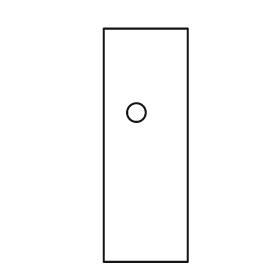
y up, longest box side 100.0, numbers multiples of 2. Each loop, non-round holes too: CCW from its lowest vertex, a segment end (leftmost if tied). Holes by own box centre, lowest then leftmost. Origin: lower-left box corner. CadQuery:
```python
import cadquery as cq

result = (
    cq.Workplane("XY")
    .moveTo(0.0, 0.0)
    .lineTo(36.0, 0.0)
    .lineTo(36.0, 100.0)
    .lineTo(0.0, 100.0)
    .close()
    .moveTo(14.0, 64.0)
    .circle(4.0)
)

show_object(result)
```